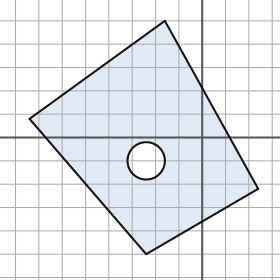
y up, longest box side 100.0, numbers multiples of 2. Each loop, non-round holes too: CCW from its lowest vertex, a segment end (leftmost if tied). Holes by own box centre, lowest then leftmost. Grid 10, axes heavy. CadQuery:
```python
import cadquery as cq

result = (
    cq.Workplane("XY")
    .moveTo(-24.0, -50.0)
    .lineTo(24.0, -22.0)
    .lineTo(-16.0, 50.0)
    .lineTo(-74.0, 8.0)
    .close()
    .moveTo(-24.0, -10.0)
    .circle(8.0)
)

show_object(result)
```